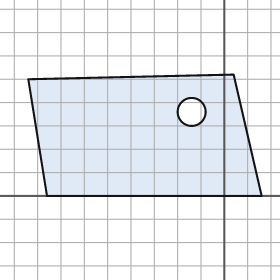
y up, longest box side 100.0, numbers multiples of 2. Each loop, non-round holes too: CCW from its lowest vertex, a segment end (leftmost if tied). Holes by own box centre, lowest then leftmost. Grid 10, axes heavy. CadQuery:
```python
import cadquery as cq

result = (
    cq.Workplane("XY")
    .moveTo(-76.0, 0.0)
    .lineTo(16.0, 0.0)
    .lineTo(4.0, 52.0)
    .lineTo(-84.0, 50.0)
    .close()
    .moveTo(-14.0, 36.0)
    .circle(6.0)
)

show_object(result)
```